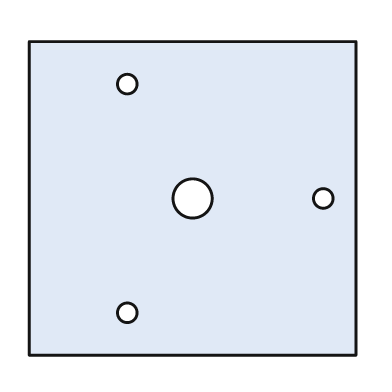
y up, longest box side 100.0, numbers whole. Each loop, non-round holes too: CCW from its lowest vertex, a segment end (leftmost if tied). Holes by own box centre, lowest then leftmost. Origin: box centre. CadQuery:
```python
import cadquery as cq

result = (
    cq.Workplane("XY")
    .moveTo(-50.0, -48.0)
    .lineTo(50.0, -48.0)
    .lineTo(50.0, 48.0)
    .lineTo(-50.0, 48.0)
    .close()
    .moveTo(-20.0, -35.0)
    .circle(3.0)
    .moveTo(0.0, 0.0)
    .circle(6.0)
    .moveTo(40.0, 0.0)
    .circle(3.0)
    .moveTo(-20.0, 35.0)
    .circle(3.0)
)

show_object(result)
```